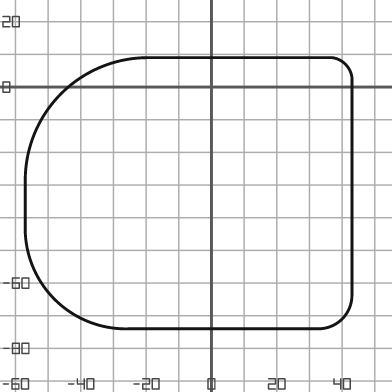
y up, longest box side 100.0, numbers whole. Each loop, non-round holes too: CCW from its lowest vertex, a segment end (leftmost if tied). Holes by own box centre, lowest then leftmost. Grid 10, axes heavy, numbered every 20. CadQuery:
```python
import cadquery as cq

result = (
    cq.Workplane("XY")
    .moveTo(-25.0, -74.0)
    .lineTo(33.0, -74.0)
    .threePointArc((40.0, -71.0), (43.0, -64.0))
    .lineTo(43.0, 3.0)
    .threePointArc((41.0, 7.0), (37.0, 9.0))
    .lineTo(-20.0, 9.0)
    .threePointArc((-46.0, -2.0), (-57.0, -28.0))
    .lineTo(-57.0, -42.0)
    .threePointArc((-48.0, -65.0), (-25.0, -74.0))
    .close()
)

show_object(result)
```